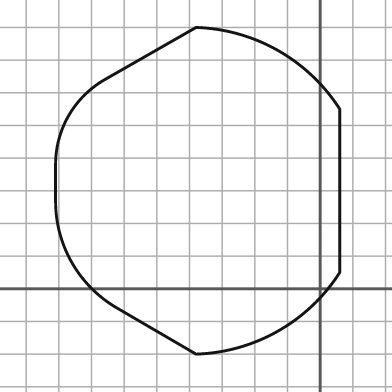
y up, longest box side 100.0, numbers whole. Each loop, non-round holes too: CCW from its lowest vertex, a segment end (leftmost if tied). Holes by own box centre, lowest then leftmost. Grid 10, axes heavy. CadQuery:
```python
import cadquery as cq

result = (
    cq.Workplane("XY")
    .moveTo(-38.0, -20.0)
    .threePointArc((-13.0, -13.0), (6.0, 5.0))
    .lineTo(6.0, 55.0)
    .threePointArc((-13.0, 73.0), (-38.0, 80.0))
    .lineTo(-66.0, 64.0)
    .threePointArc((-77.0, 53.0), (-81.0, 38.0))
    .lineTo(-81.0, 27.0)
    .threePointArc((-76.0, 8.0), (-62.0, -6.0))
    .close()
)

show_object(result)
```